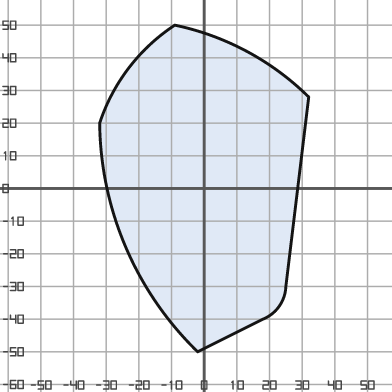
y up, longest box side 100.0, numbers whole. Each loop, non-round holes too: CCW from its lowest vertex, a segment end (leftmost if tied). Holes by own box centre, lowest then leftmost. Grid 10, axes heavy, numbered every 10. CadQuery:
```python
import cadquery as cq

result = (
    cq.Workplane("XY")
    .moveTo(-2.0, -50.0)
    .lineTo(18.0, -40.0)
    .threePointArc((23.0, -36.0), (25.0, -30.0))
    .lineTo(32.0, 28.0)
    .threePointArc((13.0, 42.0), (-9.0, 50.0))
    .threePointArc((-23.0, 37.0), (-32.0, 20.0))
    .threePointArc((-24.0, -18.0), (-2.0, -50.0))
    .close()
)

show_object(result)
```